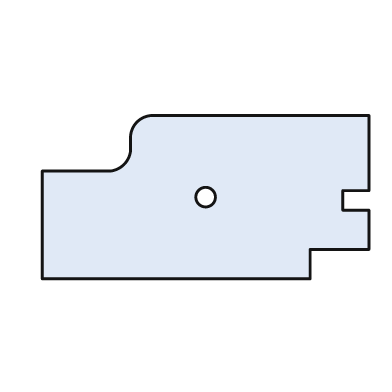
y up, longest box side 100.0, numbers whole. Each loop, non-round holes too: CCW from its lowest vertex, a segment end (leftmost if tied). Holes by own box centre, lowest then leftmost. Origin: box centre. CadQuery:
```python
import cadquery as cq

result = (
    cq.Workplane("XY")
    .moveTo(-50.0, -25.0)
    .lineTo(32.0, -25.0)
    .lineTo(32.0, -16.0)
    .lineTo(50.0, -16.0)
    .lineTo(50.0, -4.0)
    .lineTo(42.0, -4.0)
    .lineTo(42.0, 2.0)
    .lineTo(50.0, 2.0)
    .lineTo(50.0, 25.0)
    .lineTo(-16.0, 25.0)
    .threePointArc((-21.0, 23.0), (-23.0, 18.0))
    .lineTo(-23.0, 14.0)
    .threePointArc((-25.0, 10.0), (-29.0, 8.0))
    .lineTo(-50.0, 8.0)
    .close()
    .moveTo(0.0, 0.0)
    .circle(3.0)
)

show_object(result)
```